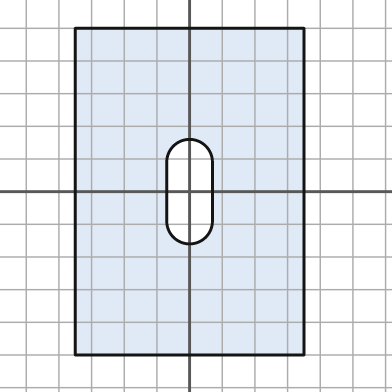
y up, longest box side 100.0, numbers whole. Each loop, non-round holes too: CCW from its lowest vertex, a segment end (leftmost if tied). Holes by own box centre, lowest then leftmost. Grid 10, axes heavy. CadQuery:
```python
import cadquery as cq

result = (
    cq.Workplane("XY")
    .moveTo(-35.0, -50.0)
    .lineTo(35.0, -50.0)
    .lineTo(35.0, 50.0)
    .lineTo(-35.0, 50.0)
    .close()
    .moveTo(-7.0, -9.0)
    .threePointArc((0.0, -16.0), (7.0, -9.0))
    .lineTo(7.0, 9.0)
    .threePointArc((0.0, 16.0), (-7.0, 9.0))
    .close()
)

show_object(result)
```